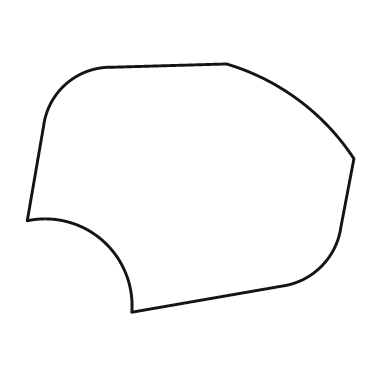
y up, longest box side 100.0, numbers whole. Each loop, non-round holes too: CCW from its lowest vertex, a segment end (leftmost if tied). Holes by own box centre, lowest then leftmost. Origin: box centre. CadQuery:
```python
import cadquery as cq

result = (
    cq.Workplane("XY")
    .moveTo(-18.0, -38.0)
    .lineTo(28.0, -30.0)
    .threePointArc((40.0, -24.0), (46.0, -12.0))
    .lineTo(50.0, 9.0)
    .threePointArc((33.0, 27.0), (11.0, 38.0))
    .lineTo(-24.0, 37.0)
    .threePointArc((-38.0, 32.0), (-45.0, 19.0))
    .lineTo(-50.0, -10.0)
    .threePointArc((-27.0, -16.0), (-18.0, -38.0))
    .close()
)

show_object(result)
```